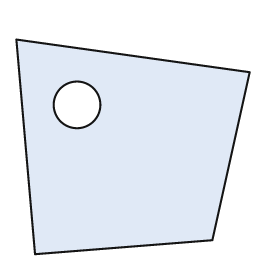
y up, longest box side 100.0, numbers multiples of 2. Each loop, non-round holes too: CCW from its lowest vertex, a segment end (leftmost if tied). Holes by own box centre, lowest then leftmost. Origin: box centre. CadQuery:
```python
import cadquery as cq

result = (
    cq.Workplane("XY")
    .moveTo(-42.0, -46.0)
    .lineTo(34.0, -40.0)
    .lineTo(50.0, 32.0)
    .lineTo(-50.0, 46.0)
    .close()
    .moveTo(-24.0, 18.0)
    .circle(10.0)
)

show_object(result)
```